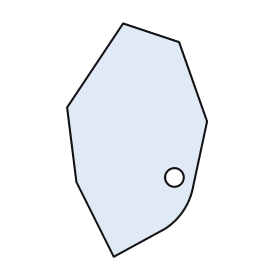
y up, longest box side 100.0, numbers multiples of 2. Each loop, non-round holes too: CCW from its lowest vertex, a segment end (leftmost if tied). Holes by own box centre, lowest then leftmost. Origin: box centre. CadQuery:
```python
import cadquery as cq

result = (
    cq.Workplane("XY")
    .moveTo(-10.0, -50.0)
    .lineTo(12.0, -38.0)
    .threePointArc((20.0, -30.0), (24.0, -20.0))
    .lineTo(30.0, 8.0)
    .lineTo(18.0, 42.0)
    .lineTo(-6.0, 50.0)
    .lineTo(-30.0, 14.0)
    .lineTo(-26.0, -18.0)
    .close()
    .moveTo(16.0, -16.0)
    .circle(4.0)
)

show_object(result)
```